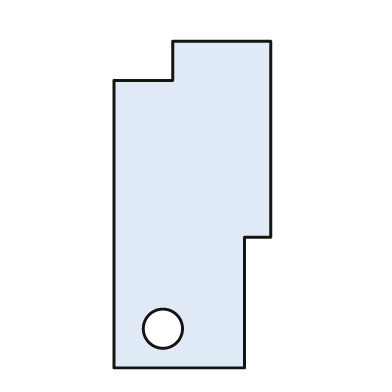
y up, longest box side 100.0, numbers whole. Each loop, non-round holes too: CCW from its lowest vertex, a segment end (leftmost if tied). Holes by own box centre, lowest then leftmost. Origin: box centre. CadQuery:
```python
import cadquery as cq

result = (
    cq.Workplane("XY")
    .moveTo(-24.0, -50.0)
    .lineTo(16.0, -50.0)
    .lineTo(16.0, -10.0)
    .lineTo(24.0, -10.0)
    .lineTo(24.0, 50.0)
    .lineTo(-6.0, 50.0)
    .lineTo(-6.0, 38.0)
    .lineTo(-24.0, 38.0)
    .close()
    .moveTo(-9.0, -38.0)
    .circle(6.0)
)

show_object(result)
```